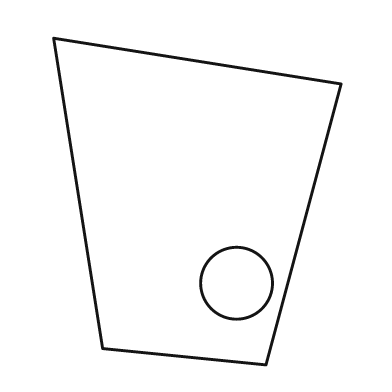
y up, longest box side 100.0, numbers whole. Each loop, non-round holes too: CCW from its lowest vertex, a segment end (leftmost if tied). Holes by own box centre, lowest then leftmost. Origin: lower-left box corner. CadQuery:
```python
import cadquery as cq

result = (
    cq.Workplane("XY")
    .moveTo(65.0, 0.0)
    .lineTo(88.0, 86.0)
    .lineTo(0.0, 100.0)
    .lineTo(15.0, 5.0)
    .close()
    .moveTo(56.0, 25.0)
    .circle(11.0)
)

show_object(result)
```